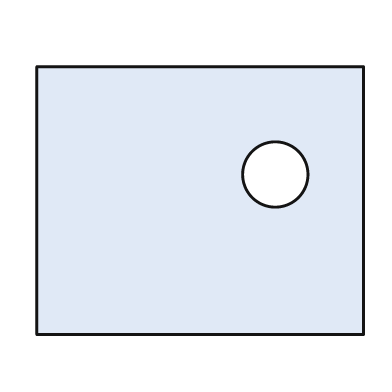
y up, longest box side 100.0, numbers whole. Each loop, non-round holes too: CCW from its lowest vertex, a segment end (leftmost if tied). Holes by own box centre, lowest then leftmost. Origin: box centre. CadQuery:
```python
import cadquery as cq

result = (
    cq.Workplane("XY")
    .moveTo(-50.0, -41.0)
    .lineTo(50.0, -41.0)
    .lineTo(50.0, 41.0)
    .lineTo(-50.0, 41.0)
    .close()
    .moveTo(23.0, 8.0)
    .circle(10.0)
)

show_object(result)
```